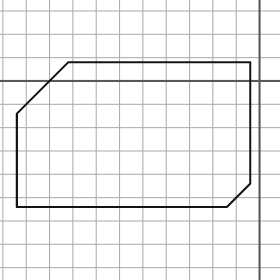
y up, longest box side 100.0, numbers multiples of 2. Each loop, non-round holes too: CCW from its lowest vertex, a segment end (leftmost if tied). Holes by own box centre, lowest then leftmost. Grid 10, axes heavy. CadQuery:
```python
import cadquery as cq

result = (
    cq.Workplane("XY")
    .moveTo(-104.0, -54.0)
    .lineTo(-14.0, -54.0)
    .lineTo(-4.0, -44.0)
    .lineTo(-4.0, 8.0)
    .lineTo(-82.0, 8.0)
    .lineTo(-104.0, -14.0)
    .close()
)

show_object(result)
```